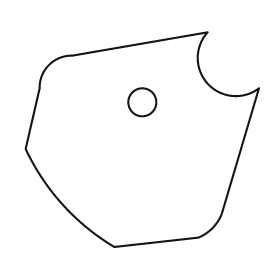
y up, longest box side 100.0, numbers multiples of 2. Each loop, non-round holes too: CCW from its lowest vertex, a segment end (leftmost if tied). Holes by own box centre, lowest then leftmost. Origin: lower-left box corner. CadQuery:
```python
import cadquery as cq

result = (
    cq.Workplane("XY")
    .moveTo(38.0, 0.0)
    .lineTo(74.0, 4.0)
    .threePointArc((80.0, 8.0), (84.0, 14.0))
    .lineTo(100.0, 68.0)
    .threePointArc((78.0, 70.0), (78.0, 92.0))
    .lineTo(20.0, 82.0)
    .threePointArc((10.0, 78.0), (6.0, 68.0))
    .lineTo(0.0, 42.0)
    .threePointArc((16.0, 18.0), (38.0, 0.0))
    .close()
    .moveTo(50.0, 62.0)
    .circle(6.0)
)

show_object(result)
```